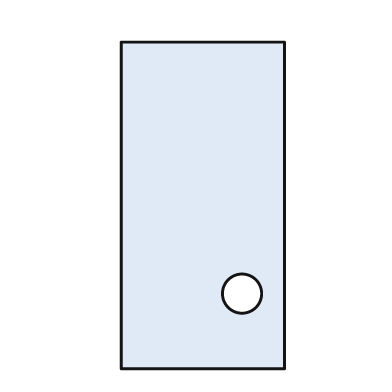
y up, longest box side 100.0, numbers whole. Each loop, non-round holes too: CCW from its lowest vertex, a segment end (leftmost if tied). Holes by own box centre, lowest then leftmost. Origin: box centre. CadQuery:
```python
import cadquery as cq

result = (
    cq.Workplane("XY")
    .moveTo(-25.0, -50.0)
    .lineTo(25.0, -50.0)
    .lineTo(25.0, 50.0)
    .lineTo(-25.0, 50.0)
    .close()
    .moveTo(12.0, -27.0)
    .circle(6.0)
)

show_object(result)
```